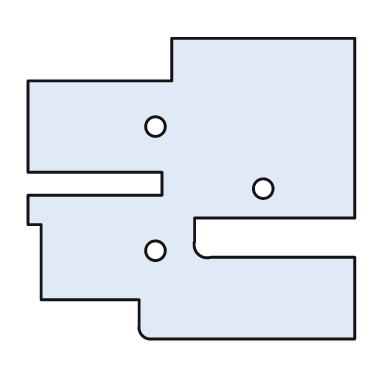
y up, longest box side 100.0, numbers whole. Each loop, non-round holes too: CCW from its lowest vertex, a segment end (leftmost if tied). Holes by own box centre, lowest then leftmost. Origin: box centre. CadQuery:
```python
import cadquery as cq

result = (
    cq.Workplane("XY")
    .moveTo(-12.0, -46.0)
    .lineTo(50.0, -46.0)
    .lineTo(50.0, -21.0)
    .lineTo(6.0, -21.0)
    .threePointArc((2.0, -20.0), (1.0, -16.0))
    .lineTo(1.0, -9.0)
    .lineTo(50.0, -9.0)
    .lineTo(50.0, 46.0)
    .lineTo(-6.0, 46.0)
    .lineTo(-6.0, 33.0)
    .lineTo(-50.0, 33.0)
    .lineTo(-50.0, 5.0)
    .lineTo(-9.0, 5.0)
    .lineTo(-9.0, -2.0)
    .lineTo(-50.0, -2.0)
    .lineTo(-50.0, -11.0)
    .lineTo(-46.0, -11.0)
    .lineTo(-46.0, -34.0)
    .lineTo(-16.0, -34.0)
    .lineTo(-16.0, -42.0)
    .threePointArc((-15.0, -45.0), (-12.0, -46.0))
    .close()
    .moveTo(-11.0, -19.0)
    .circle(3.0)
    .moveTo(22.0, 0.0)
    .circle(3.0)
    .moveTo(-11.0, 19.0)
    .circle(3.0)
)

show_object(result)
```